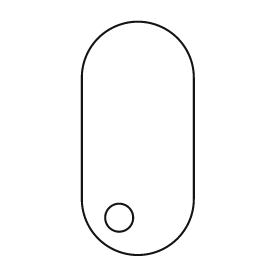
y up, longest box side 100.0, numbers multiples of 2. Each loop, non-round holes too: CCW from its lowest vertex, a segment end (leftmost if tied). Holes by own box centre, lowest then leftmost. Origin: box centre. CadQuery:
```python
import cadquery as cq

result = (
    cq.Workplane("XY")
    .moveTo(-24.0, -26.0)
    .threePointArc((0.0, -50.0), (24.0, -26.0))
    .lineTo(24.0, 26.0)
    .threePointArc((0.0, 50.0), (-24.0, 26.0))
    .close()
    .moveTo(-8.0, -34.0)
    .circle(6.0)
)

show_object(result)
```